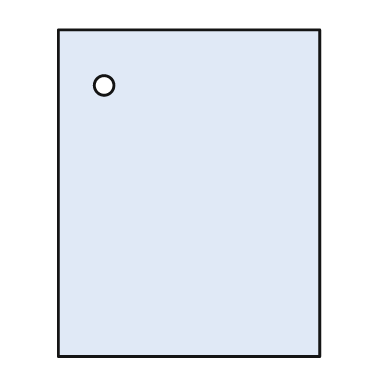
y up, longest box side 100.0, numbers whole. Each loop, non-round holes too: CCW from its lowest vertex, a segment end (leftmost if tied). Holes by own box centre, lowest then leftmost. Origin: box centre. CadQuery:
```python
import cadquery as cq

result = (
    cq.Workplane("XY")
    .moveTo(-40.0, -50.0)
    .lineTo(40.0, -50.0)
    .lineTo(40.0, 50.0)
    .lineTo(-40.0, 50.0)
    .close()
    .moveTo(-26.0, 33.0)
    .circle(3.0)
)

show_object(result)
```